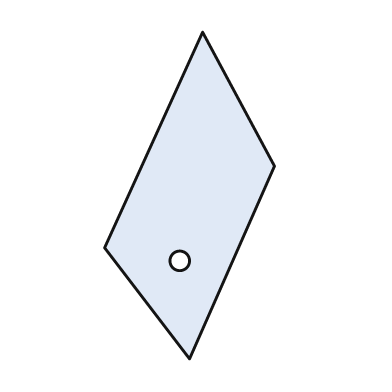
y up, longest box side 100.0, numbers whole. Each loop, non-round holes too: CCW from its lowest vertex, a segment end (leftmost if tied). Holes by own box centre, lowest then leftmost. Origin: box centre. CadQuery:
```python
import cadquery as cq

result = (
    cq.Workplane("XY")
    .moveTo(0.0, -50.0)
    .lineTo(26.0, 9.0)
    .lineTo(4.0, 50.0)
    .lineTo(-26.0, -16.0)
    .close()
    .moveTo(-3.0, -20.0)
    .circle(3.0)
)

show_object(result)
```